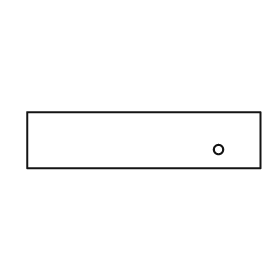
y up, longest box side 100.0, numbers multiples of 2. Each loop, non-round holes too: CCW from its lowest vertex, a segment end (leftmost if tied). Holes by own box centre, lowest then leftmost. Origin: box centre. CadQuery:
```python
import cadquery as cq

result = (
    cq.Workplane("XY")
    .moveTo(-50.0, -12.0)
    .lineTo(50.0, -12.0)
    .lineTo(50.0, 12.0)
    .lineTo(-50.0, 12.0)
    .close()
    .moveTo(32.0, -4.0)
    .circle(2.0)
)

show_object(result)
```